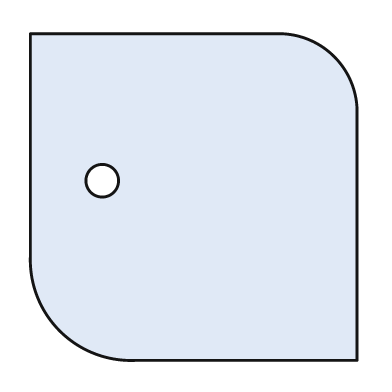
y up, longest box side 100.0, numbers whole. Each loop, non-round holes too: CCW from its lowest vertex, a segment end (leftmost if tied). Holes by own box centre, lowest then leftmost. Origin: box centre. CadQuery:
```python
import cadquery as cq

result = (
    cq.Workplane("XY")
    .moveTo(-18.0, -50.0)
    .lineTo(50.0, -50.0)
    .lineTo(50.0, 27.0)
    .threePointArc((43.0, 43.0), (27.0, 50.0))
    .lineTo(-50.0, 50.0)
    .lineTo(-50.0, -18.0)
    .threePointArc((-41.0, -41.0), (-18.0, -50.0))
    .close()
    .moveTo(-28.0, 5.0)
    .circle(5.0)
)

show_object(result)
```